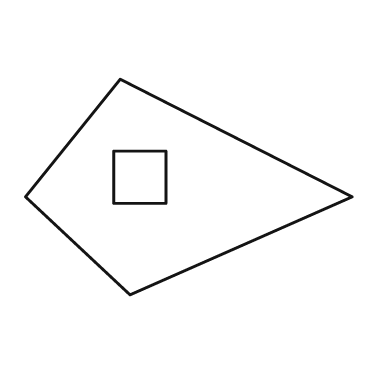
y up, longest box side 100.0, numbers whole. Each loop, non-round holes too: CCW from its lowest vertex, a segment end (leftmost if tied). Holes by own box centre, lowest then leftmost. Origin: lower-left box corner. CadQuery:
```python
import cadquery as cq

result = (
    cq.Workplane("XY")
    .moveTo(32.0, 0.0)
    .lineTo(100.0, 30.0)
    .lineTo(29.0, 66.0)
    .lineTo(0.0, 30.0)
    .close()
    .moveTo(27.0, 28.0)
    .lineTo(43.0, 28.0)
    .lineTo(43.0, 44.0)
    .lineTo(27.0, 44.0)
    .close()
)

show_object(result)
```